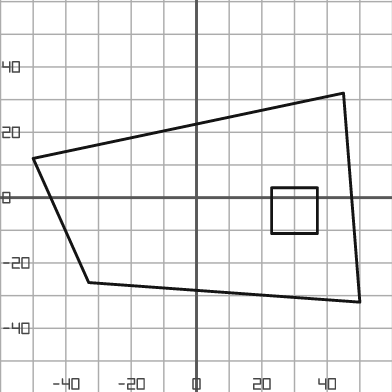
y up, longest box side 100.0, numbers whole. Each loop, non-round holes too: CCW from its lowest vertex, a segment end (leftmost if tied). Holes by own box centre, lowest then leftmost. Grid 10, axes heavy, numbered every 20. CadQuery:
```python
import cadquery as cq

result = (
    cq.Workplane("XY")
    .moveTo(50.0, -32.0)
    .lineTo(45.0, 32.0)
    .lineTo(-50.0, 12.0)
    .lineTo(-33.0, -26.0)
    .close()
    .moveTo(23.0, -11.0)
    .lineTo(37.0, -11.0)
    .lineTo(37.0, 3.0)
    .lineTo(23.0, 3.0)
    .close()
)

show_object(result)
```